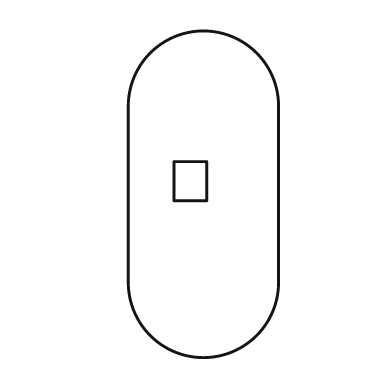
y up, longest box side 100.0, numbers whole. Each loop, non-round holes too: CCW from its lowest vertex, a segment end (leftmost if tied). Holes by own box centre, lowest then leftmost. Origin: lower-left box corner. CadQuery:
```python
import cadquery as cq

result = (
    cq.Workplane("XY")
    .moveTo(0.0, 23.0)
    .threePointArc((23.0, 0.0), (46.0, 23.0))
    .lineTo(46.0, 77.0)
    .threePointArc((23.0, 100.0), (0.0, 77.0))
    .close()
    .moveTo(14.0, 48.0)
    .lineTo(24.0, 48.0)
    .lineTo(24.0, 60.0)
    .lineTo(14.0, 60.0)
    .close()
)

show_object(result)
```